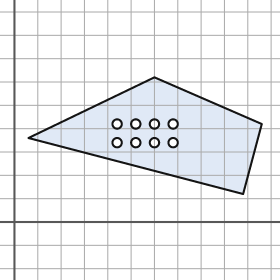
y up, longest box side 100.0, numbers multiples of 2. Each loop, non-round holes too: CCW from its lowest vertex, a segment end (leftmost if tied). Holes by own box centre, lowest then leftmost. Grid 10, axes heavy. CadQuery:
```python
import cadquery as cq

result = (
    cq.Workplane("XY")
    .moveTo(98.0, 12.0)
    .lineTo(106.0, 42.0)
    .lineTo(60.0, 62.0)
    .lineTo(6.0, 36.0)
    .close()
    .moveTo(44.0, 34.0)
    .circle(2.0)
    .moveTo(52.0, 34.0)
    .circle(2.0)
    .moveTo(60.0, 34.0)
    .circle(2.0)
    .moveTo(68.0, 34.0)
    .circle(2.0)
    .moveTo(44.0, 42.0)
    .circle(2.0)
    .moveTo(52.0, 42.0)
    .circle(2.0)
    .moveTo(60.0, 42.0)
    .circle(2.0)
    .moveTo(68.0, 42.0)
    .circle(2.0)
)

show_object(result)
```